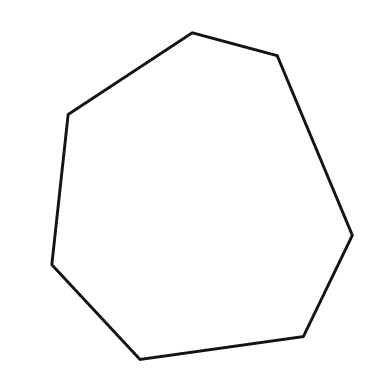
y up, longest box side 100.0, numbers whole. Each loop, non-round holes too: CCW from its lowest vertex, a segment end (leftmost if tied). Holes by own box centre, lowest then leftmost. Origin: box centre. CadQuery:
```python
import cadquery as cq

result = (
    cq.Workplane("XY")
    .moveTo(-19.0, -50.0)
    .lineTo(31.0, -43.0)
    .lineTo(46.0, -12.0)
    .lineTo(23.0, 43.0)
    .lineTo(-3.0, 50.0)
    .lineTo(-41.0, 25.0)
    .lineTo(-46.0, -21.0)
    .close()
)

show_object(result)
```